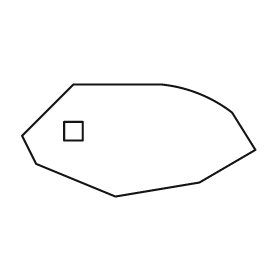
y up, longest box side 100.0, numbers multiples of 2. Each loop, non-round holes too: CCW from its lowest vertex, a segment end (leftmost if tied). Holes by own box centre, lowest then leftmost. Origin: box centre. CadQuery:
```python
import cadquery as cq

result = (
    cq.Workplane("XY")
    .moveTo(-10.0, -24.0)
    .lineTo(26.0, -18.0)
    .lineTo(50.0, -4.0)
    .lineTo(40.0, 12.0)
    .threePointArc((26.0, 20.0), (10.0, 24.0))
    .lineTo(-28.0, 24.0)
    .lineTo(-50.0, 2.0)
    .lineTo(-44.0, -10.0)
    .close()
    .moveTo(-32.0, 0.0)
    .lineTo(-24.0, 0.0)
    .lineTo(-24.0, 8.0)
    .lineTo(-32.0, 8.0)
    .close()
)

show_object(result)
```